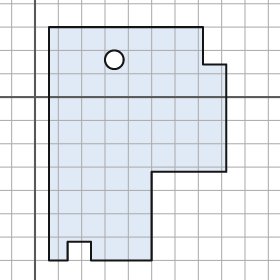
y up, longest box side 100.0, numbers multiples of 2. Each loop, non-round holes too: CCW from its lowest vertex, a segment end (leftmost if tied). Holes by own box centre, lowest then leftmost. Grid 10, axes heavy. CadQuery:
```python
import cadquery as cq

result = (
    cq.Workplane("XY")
    .moveTo(6.0, -70.0)
    .lineTo(14.0, -70.0)
    .lineTo(14.0, -62.0)
    .lineTo(24.0, -62.0)
    .lineTo(24.0, -70.0)
    .lineTo(50.0, -70.0)
    .lineTo(50.0, -32.0)
    .lineTo(82.0, -32.0)
    .lineTo(82.0, 14.0)
    .lineTo(72.0, 14.0)
    .lineTo(72.0, 30.0)
    .lineTo(6.0, 30.0)
    .close()
    .moveTo(34.0, 16.0)
    .circle(4.0)
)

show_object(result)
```